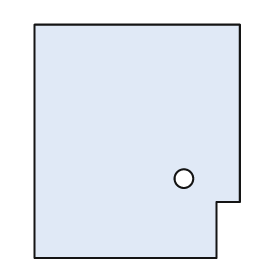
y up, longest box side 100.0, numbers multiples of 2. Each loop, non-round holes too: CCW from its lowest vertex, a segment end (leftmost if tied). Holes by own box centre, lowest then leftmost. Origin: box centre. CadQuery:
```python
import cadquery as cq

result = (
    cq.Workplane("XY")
    .moveTo(-44.0, -50.0)
    .lineTo(34.0, -50.0)
    .lineTo(34.0, -26.0)
    .lineTo(44.0, -26.0)
    .lineTo(44.0, 50.0)
    .lineTo(-44.0, 50.0)
    .close()
    .moveTo(20.0, -16.0)
    .circle(4.0)
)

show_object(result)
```